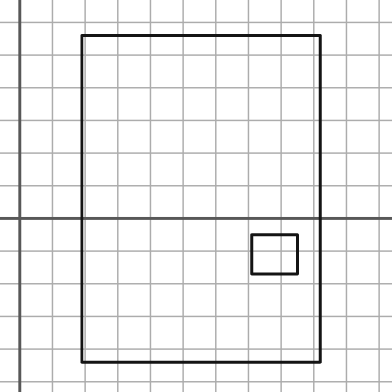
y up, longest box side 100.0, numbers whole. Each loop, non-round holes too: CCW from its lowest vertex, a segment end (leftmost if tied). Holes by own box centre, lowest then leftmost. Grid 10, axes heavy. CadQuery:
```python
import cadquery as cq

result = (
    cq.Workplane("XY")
    .moveTo(19.0, -44.0)
    .lineTo(92.0, -44.0)
    .lineTo(92.0, 56.0)
    .lineTo(19.0, 56.0)
    .close()
    .moveTo(71.0, -17.0)
    .lineTo(85.0, -17.0)
    .lineTo(85.0, -5.0)
    .lineTo(71.0, -5.0)
    .close()
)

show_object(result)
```